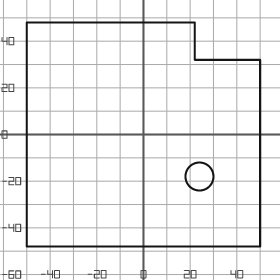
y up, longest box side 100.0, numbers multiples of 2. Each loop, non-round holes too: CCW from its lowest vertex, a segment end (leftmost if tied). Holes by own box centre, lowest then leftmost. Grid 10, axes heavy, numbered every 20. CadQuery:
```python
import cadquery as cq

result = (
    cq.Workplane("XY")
    .moveTo(-50.0, -48.0)
    .lineTo(50.0, -48.0)
    .lineTo(50.0, 32.0)
    .lineTo(22.0, 32.0)
    .lineTo(22.0, 48.0)
    .lineTo(-50.0, 48.0)
    .close()
    .moveTo(24.0, -18.0)
    .circle(6.0)
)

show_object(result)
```